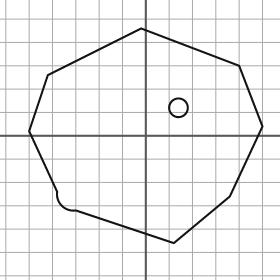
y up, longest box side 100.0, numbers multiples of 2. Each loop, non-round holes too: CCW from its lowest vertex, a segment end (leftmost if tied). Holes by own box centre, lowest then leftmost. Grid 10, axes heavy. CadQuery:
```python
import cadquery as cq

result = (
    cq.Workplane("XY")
    .moveTo(12.0, -46.0)
    .lineTo(36.0, -26.0)
    .lineTo(50.0, 4.0)
    .lineTo(40.0, 30.0)
    .lineTo(-2.0, 46.0)
    .lineTo(-42.0, 26.0)
    .lineTo(-50.0, 2.0)
    .lineTo(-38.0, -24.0)
    .threePointArc((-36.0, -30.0), (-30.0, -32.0))
    .close()
    .moveTo(14.0, 12.0)
    .circle(4.0)
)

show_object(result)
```